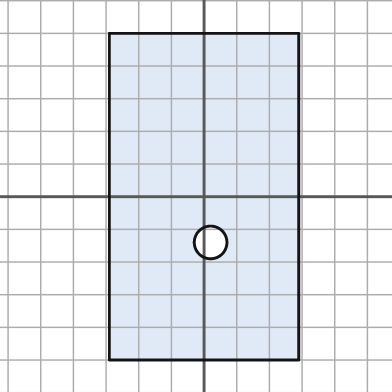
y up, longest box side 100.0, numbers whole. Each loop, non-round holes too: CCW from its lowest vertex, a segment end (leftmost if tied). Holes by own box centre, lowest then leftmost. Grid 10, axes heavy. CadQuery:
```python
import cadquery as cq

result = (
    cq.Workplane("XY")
    .moveTo(-29.0, -50.0)
    .lineTo(29.0, -50.0)
    .lineTo(29.0, 50.0)
    .lineTo(-29.0, 50.0)
    .close()
    .moveTo(2.0, -14.0)
    .circle(5.0)
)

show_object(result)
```